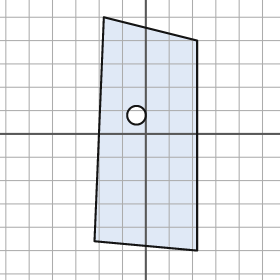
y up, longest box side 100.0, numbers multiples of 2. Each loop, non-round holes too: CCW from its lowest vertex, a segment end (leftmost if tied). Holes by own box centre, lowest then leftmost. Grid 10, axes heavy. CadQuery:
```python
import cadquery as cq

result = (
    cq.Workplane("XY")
    .moveTo(22.0, -50.0)
    .lineTo(22.0, 40.0)
    .lineTo(-18.0, 50.0)
    .lineTo(-22.0, -46.0)
    .close()
    .moveTo(-4.0, 8.0)
    .circle(4.0)
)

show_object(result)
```